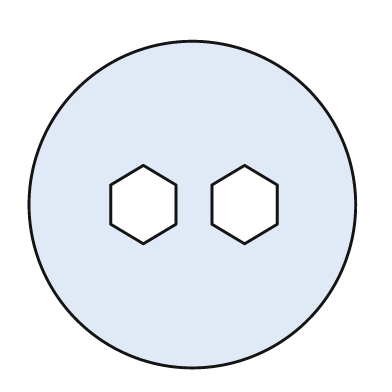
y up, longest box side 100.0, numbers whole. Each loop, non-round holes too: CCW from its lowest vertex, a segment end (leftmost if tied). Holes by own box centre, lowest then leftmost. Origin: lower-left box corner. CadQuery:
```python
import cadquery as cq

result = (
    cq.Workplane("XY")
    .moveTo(50.0, 50.0)
    .circle(50.0)
    .moveTo(35.0, 38.0)
    .lineTo(45.0, 44.0)
    .lineTo(45.0, 56.0)
    .lineTo(35.0, 62.0)
    .lineTo(25.0, 56.0)
    .lineTo(25.0, 44.0)
    .close()
    .moveTo(66.0, 38.0)
    .lineTo(76.0, 44.0)
    .lineTo(76.0, 56.0)
    .lineTo(66.0, 62.0)
    .lineTo(56.0, 56.0)
    .lineTo(56.0, 44.0)
    .close()
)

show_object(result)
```